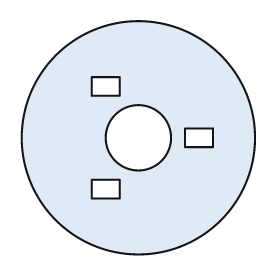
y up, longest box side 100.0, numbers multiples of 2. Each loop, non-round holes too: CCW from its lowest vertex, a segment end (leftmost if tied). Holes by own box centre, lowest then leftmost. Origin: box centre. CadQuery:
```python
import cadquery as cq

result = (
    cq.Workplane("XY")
    .moveTo(0.0, 0.0)
    .circle(50.0)
    .moveTo(-20.0, -26.0)
    .lineTo(-8.0, -26.0)
    .lineTo(-8.0, -18.0)
    .lineTo(-20.0, -18.0)
    .close()
    .moveTo(0.0, 0.0)
    .circle(14.0)
    .moveTo(20.0, -4.0)
    .lineTo(32.0, -4.0)
    .lineTo(32.0, 4.0)
    .lineTo(20.0, 4.0)
    .close()
    .moveTo(-20.0, 18.0)
    .lineTo(-8.0, 18.0)
    .lineTo(-8.0, 26.0)
    .lineTo(-20.0, 26.0)
    .close()
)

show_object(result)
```